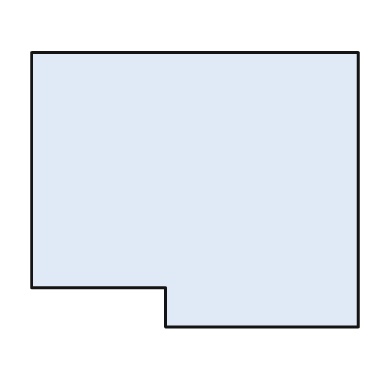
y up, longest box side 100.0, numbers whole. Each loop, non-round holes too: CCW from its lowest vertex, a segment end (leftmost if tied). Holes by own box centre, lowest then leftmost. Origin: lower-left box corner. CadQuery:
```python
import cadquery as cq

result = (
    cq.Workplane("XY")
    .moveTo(41.0, 0.0)
    .lineTo(100.0, 0.0)
    .lineTo(100.0, 84.0)
    .lineTo(0.0, 84.0)
    .lineTo(0.0, 12.0)
    .lineTo(41.0, 12.0)
    .close()
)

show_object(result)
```